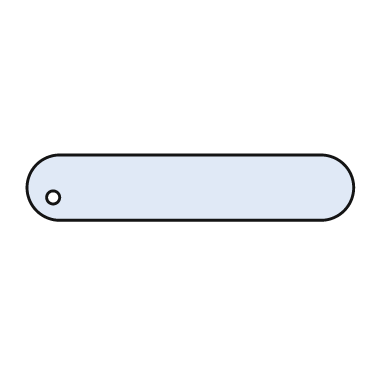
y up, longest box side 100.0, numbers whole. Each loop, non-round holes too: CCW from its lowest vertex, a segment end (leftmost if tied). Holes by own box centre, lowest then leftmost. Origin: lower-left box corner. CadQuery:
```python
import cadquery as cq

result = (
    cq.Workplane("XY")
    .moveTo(10.0, 0.0)
    .lineTo(90.0, 0.0)
    .threePointArc((100.0, 10.0), (90.0, 20.0))
    .lineTo(10.0, 20.0)
    .threePointArc((0.0, 10.0), (10.0, 0.0))
    .close()
    .moveTo(8.0, 7.0)
    .circle(2.0)
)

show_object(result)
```